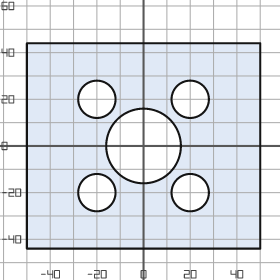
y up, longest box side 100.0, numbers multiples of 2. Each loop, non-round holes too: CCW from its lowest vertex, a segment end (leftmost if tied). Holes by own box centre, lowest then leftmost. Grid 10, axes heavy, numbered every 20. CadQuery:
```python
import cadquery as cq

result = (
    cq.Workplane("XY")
    .moveTo(-50.0, -44.0)
    .lineTo(50.0, -44.0)
    .lineTo(50.0, 44.0)
    .lineTo(-50.0, 44.0)
    .close()
    .moveTo(-20.0, -20.0)
    .circle(8.0)
    .moveTo(20.0, -20.0)
    .circle(8.0)
    .moveTo(0.0, 0.0)
    .circle(16.0)
    .moveTo(-20.0, 20.0)
    .circle(8.0)
    .moveTo(20.0, 20.0)
    .circle(8.0)
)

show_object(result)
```